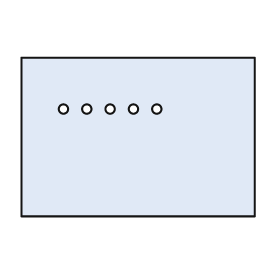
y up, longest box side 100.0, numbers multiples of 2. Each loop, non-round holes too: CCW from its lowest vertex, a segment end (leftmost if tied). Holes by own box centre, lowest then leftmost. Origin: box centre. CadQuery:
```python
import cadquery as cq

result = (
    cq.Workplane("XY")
    .moveTo(-50.0, -34.0)
    .lineTo(50.0, -34.0)
    .lineTo(50.0, 34.0)
    .lineTo(-50.0, 34.0)
    .close()
    .moveTo(-32.0, 12.0)
    .circle(2.0)
    .moveTo(-22.0, 12.0)
    .circle(2.0)
    .moveTo(-12.0, 12.0)
    .circle(2.0)
    .moveTo(-2.0, 12.0)
    .circle(2.0)
    .moveTo(8.0, 12.0)
    .circle(2.0)
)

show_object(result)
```